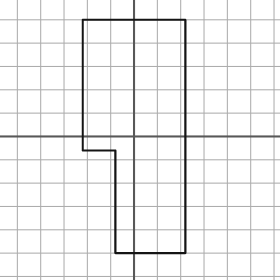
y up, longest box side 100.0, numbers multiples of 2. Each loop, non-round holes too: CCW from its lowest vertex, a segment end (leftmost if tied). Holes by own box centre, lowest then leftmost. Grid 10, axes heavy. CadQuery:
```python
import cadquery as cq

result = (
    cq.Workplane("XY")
    .moveTo(-8.0, -50.0)
    .lineTo(22.0, -50.0)
    .lineTo(22.0, 50.0)
    .lineTo(-22.0, 50.0)
    .lineTo(-22.0, -6.0)
    .lineTo(-8.0, -6.0)
    .close()
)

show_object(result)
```